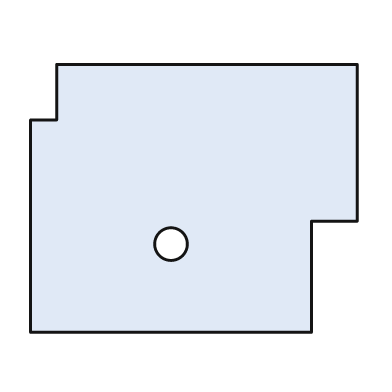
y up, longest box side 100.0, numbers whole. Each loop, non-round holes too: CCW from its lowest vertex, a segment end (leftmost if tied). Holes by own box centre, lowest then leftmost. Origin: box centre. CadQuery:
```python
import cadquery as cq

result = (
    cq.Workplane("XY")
    .moveTo(-50.0, -41.0)
    .lineTo(36.0, -41.0)
    .lineTo(36.0, -7.0)
    .lineTo(50.0, -7.0)
    .lineTo(50.0, 41.0)
    .lineTo(-42.0, 41.0)
    .lineTo(-42.0, 24.0)
    .lineTo(-50.0, 24.0)
    .close()
    .moveTo(-7.0, -14.0)
    .circle(5.0)
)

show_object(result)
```